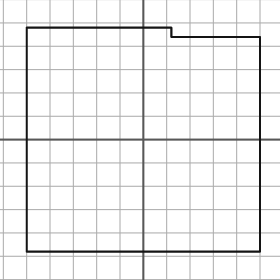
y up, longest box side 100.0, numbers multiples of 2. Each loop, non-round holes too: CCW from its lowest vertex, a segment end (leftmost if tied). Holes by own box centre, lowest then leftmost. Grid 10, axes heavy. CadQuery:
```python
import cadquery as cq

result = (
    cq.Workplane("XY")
    .moveTo(-50.0, -48.0)
    .lineTo(50.0, -48.0)
    .lineTo(50.0, 44.0)
    .lineTo(12.0, 44.0)
    .lineTo(12.0, 48.0)
    .lineTo(-50.0, 48.0)
    .close()
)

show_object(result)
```